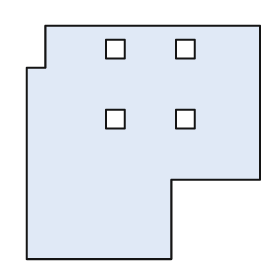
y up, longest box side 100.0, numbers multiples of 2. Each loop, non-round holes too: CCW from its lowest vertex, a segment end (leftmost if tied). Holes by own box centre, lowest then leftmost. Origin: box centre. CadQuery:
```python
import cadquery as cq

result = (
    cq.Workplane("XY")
    .moveTo(-50.0, -50.0)
    .lineTo(12.0, -50.0)
    .lineTo(12.0, -16.0)
    .lineTo(50.0, -16.0)
    .lineTo(50.0, 50.0)
    .lineTo(-42.0, 50.0)
    .lineTo(-42.0, 32.0)
    .lineTo(-50.0, 32.0)
    .close()
    .moveTo(-16.0, 6.0)
    .lineTo(-8.0, 6.0)
    .lineTo(-8.0, 14.0)
    .lineTo(-16.0, 14.0)
    .close()
    .moveTo(14.0, 6.0)
    .lineTo(22.0, 6.0)
    .lineTo(22.0, 14.0)
    .lineTo(14.0, 14.0)
    .close()
    .moveTo(-16.0, 36.0)
    .lineTo(-8.0, 36.0)
    .lineTo(-8.0, 44.0)
    .lineTo(-16.0, 44.0)
    .close()
    .moveTo(14.0, 36.0)
    .lineTo(22.0, 36.0)
    .lineTo(22.0, 44.0)
    .lineTo(14.0, 44.0)
    .close()
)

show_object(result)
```